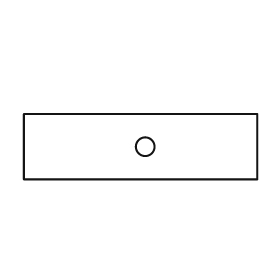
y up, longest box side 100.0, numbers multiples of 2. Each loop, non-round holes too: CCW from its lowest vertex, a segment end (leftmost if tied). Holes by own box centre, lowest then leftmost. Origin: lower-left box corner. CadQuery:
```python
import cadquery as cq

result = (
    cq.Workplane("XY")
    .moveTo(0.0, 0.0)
    .lineTo(100.0, 0.0)
    .lineTo(100.0, 28.0)
    .lineTo(0.0, 28.0)
    .close()
    .moveTo(52.0, 14.0)
    .circle(4.0)
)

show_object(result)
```